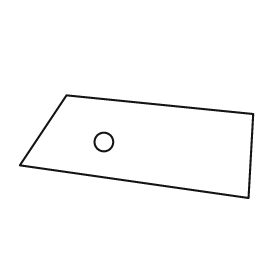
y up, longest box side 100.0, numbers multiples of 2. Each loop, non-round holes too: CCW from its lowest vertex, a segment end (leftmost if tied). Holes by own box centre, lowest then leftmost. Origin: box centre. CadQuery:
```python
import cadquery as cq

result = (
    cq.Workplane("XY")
    .moveTo(48.0, -22.0)
    .lineTo(50.0, 14.0)
    .lineTo(-30.0, 22.0)
    .lineTo(-50.0, -8.0)
    .close()
    .moveTo(-14.0, 2.0)
    .circle(4.0)
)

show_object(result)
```